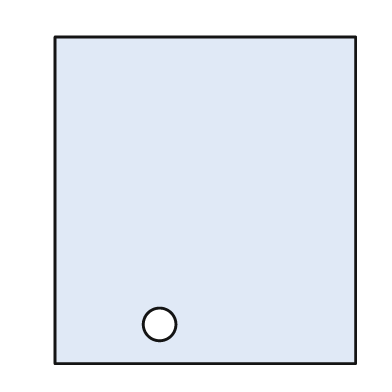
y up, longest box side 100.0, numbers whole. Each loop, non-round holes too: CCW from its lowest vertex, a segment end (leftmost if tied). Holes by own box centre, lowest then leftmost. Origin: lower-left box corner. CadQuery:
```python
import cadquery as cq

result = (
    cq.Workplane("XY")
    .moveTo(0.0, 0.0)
    .lineTo(92.0, 0.0)
    .lineTo(92.0, 100.0)
    .lineTo(0.0, 100.0)
    .close()
    .moveTo(32.0, 12.0)
    .circle(5.0)
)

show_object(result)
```